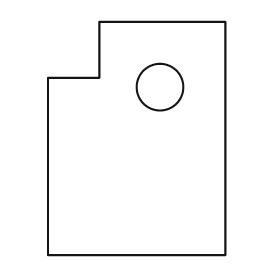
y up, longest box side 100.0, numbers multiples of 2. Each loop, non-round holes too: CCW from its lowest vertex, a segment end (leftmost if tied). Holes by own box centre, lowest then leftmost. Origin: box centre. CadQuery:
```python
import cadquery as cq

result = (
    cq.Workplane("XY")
    .moveTo(-38.0, -50.0)
    .lineTo(38.0, -50.0)
    .lineTo(38.0, 50.0)
    .lineTo(-16.0, 50.0)
    .lineTo(-16.0, 26.0)
    .lineTo(-38.0, 26.0)
    .close()
    .moveTo(10.0, 22.0)
    .circle(10.0)
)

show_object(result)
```